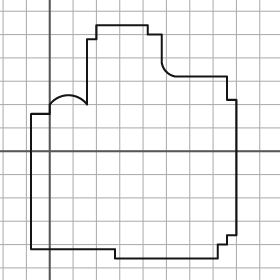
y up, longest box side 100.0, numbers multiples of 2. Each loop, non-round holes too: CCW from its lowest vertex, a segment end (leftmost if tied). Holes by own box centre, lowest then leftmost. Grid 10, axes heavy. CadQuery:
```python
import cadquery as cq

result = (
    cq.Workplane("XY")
    .moveTo(28.0, -46.0)
    .lineTo(72.0, -46.0)
    .lineTo(72.0, -40.0)
    .lineTo(76.0, -40.0)
    .lineTo(76.0, -36.0)
    .lineTo(80.0, -36.0)
    .lineTo(80.0, 22.0)
    .lineTo(76.0, 22.0)
    .lineTo(76.0, 32.0)
    .lineTo(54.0, 32.0)
    .threePointArc((50.0, 34.0), (48.0, 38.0))
    .lineTo(48.0, 50.0)
    .lineTo(42.0, 50.0)
    .lineTo(42.0, 54.0)
    .lineTo(20.0, 54.0)
    .lineTo(20.0, 48.0)
    .lineTo(16.0, 48.0)
    .lineTo(16.0, 20.0)
    .threePointArc((8.0, 24.0), (0.0, 20.0))
    .lineTo(0.0, 16.0)
    .lineTo(-8.0, 16.0)
    .lineTo(-8.0, -42.0)
    .lineTo(28.0, -42.0)
    .close()
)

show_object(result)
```